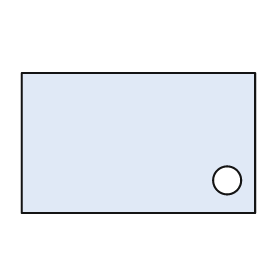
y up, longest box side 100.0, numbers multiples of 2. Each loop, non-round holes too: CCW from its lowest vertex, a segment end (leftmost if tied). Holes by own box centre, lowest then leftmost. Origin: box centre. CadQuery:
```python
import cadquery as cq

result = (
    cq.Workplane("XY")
    .moveTo(-50.0, -30.0)
    .lineTo(50.0, -30.0)
    .lineTo(50.0, 30.0)
    .lineTo(-50.0, 30.0)
    .close()
    .moveTo(38.0, -16.0)
    .circle(6.0)
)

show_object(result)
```